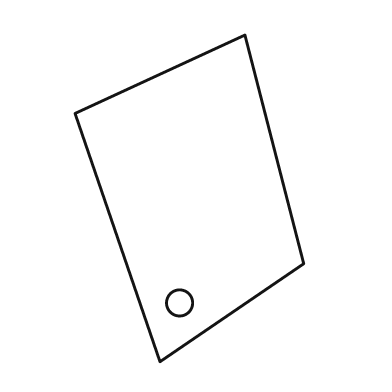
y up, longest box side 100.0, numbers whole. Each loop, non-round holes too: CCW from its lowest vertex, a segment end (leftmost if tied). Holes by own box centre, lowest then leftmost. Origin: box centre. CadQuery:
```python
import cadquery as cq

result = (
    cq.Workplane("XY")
    .moveTo(-9.0, -50.0)
    .lineTo(35.0, -20.0)
    .lineTo(17.0, 50.0)
    .lineTo(-35.0, 26.0)
    .close()
    .moveTo(-3.0, -32.0)
    .circle(4.0)
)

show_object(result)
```